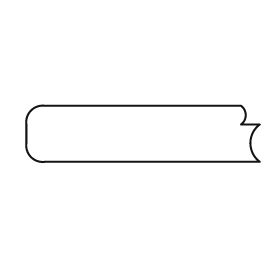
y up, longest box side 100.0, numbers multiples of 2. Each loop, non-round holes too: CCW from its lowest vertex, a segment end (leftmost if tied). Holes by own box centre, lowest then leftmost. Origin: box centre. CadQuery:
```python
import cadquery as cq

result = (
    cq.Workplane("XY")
    .moveTo(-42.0, -12.0)
    .lineTo(50.0, -12.0)
    .threePointArc((46.0, -4.0), (50.0, 4.0))
    .lineTo(42.0, 4.0)
    .threePointArc((44.0, 8.0), (42.0, 12.0))
    .lineTo(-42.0, 12.0)
    .threePointArc((-48.0, 10.0), (-50.0, 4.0))
    .lineTo(-50.0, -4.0)
    .threePointArc((-48.0, -10.0), (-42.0, -12.0))
    .close()
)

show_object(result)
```